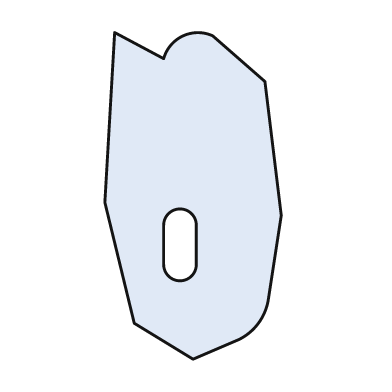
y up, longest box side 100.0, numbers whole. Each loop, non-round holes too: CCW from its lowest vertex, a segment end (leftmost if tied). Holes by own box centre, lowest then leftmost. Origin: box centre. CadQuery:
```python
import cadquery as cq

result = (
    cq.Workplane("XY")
    .moveTo(0.0, -50.0)
    .lineTo(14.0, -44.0)
    .threePointArc((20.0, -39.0), (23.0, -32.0))
    .lineTo(27.0, -6.0)
    .lineTo(22.0, 35.0)
    .lineTo(6.0, 49.0)
    .threePointArc((-3.0, 49.0), (-9.0, 42.0))
    .lineTo(-24.0, 50.0)
    .lineTo(-27.0, -2.0)
    .lineTo(-18.0, -39.0)
    .close()
    .moveTo(-9.0, -21.0)
    .threePointArc((-4.0, -26.0), (1.0, -21.0))
    .lineTo(1.0, -9.0)
    .threePointArc((-4.0, -4.0), (-9.0, -9.0))
    .close()
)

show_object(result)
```